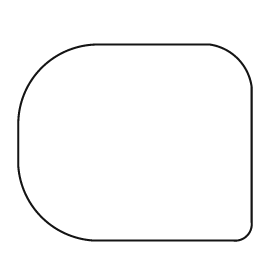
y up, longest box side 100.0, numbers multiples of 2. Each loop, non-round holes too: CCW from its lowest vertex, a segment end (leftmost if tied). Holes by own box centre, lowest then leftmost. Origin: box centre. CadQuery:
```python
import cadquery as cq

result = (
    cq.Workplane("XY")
    .moveTo(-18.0, -42.0)
    .lineTo(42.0, -42.0)
    .threePointArc((48.0, -40.0), (50.0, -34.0))
    .lineTo(50.0, 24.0)
    .threePointArc((44.0, 36.0), (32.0, 42.0))
    .lineTo(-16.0, 42.0)
    .threePointArc((-40.0, 32.0), (-50.0, 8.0))
    .lineTo(-50.0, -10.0)
    .threePointArc((-40.0, -32.0), (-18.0, -42.0))
    .close()
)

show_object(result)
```